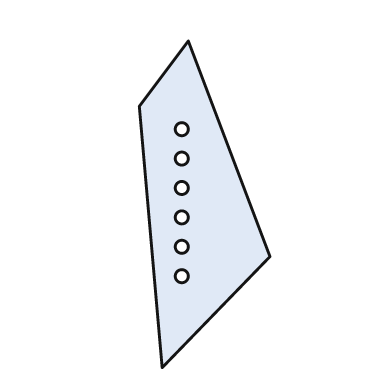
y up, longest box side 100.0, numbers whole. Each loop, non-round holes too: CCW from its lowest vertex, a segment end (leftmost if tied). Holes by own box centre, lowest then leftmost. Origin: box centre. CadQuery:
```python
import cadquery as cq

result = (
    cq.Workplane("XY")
    .moveTo(-13.0, -50.0)
    .lineTo(20.0, -16.0)
    .lineTo(-5.0, 50.0)
    .lineTo(-20.0, 30.0)
    .close()
    .moveTo(-7.0, -22.0)
    .circle(2.0)
    .moveTo(-7.0, -13.0)
    .circle(2.0)
    .moveTo(-7.0, -4.0)
    .circle(2.0)
    .moveTo(-7.0, 5.0)
    .circle(2.0)
    .moveTo(-7.0, 14.0)
    .circle(2.0)
    .moveTo(-7.0, 23.0)
    .circle(2.0)
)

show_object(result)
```